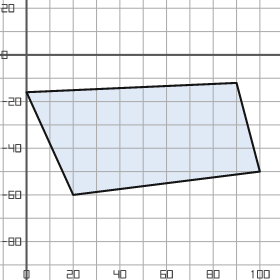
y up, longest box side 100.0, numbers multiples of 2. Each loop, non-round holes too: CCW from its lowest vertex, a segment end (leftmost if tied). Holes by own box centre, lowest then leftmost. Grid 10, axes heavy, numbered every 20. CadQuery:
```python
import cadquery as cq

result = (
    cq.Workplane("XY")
    .moveTo(20.0, -60.0)
    .lineTo(100.0, -50.0)
    .lineTo(90.0, -12.0)
    .lineTo(0.0, -16.0)
    .close()
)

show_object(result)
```